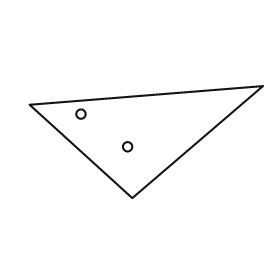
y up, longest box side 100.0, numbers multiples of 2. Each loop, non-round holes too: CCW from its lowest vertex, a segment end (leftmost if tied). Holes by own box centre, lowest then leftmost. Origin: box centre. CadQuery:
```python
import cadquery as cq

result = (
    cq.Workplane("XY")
    .moveTo(-6.0, -24.0)
    .lineTo(50.0, 24.0)
    .lineTo(-50.0, 16.0)
    .close()
    .moveTo(-8.0, -2.0)
    .circle(2.0)
    .moveTo(-28.0, 12.0)
    .circle(2.0)
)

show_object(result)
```